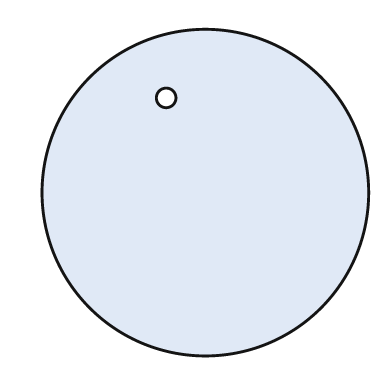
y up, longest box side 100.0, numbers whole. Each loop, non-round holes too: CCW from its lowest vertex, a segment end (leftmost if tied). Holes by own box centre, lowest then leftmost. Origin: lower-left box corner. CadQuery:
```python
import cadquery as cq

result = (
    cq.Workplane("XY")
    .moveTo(50.0, 50.0)
    .circle(50.0)
    .moveTo(38.0, 79.0)
    .circle(3.0)
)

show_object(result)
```